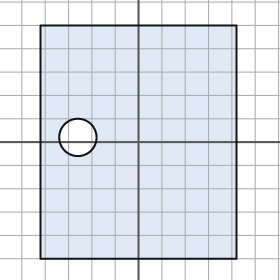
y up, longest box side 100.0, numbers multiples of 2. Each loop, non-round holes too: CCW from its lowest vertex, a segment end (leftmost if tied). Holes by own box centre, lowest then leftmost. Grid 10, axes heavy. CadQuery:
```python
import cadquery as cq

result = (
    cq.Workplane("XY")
    .moveTo(-42.0, -50.0)
    .lineTo(42.0, -50.0)
    .lineTo(42.0, 50.0)
    .lineTo(-42.0, 50.0)
    .close()
    .moveTo(-26.0, 2.0)
    .circle(8.0)
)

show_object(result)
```